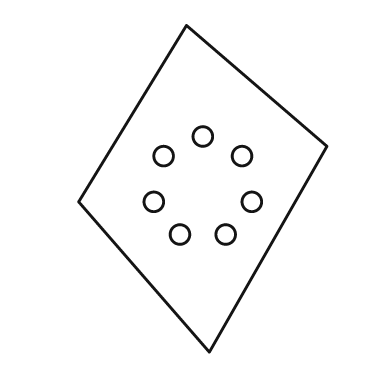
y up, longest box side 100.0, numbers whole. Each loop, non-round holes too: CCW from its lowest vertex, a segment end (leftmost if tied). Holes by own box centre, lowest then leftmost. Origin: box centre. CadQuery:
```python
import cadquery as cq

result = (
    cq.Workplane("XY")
    .moveTo(2.0, -50.0)
    .lineTo(38.0, 13.0)
    .lineTo(-5.0, 50.0)
    .lineTo(-38.0, -4.0)
    .close()
    .moveTo(-7.0, -14.0)
    .circle(3.0)
    .moveTo(7.0, -14.0)
    .circle(3.0)
    .moveTo(-15.0, -4.0)
    .circle(3.0)
    .moveTo(15.0, -4.0)
    .circle(3.0)
    .moveTo(-12.0, 10.0)
    .circle(3.0)
    .moveTo(12.0, 10.0)
    .circle(3.0)
    .moveTo(0.0, 16.0)
    .circle(3.0)
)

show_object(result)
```